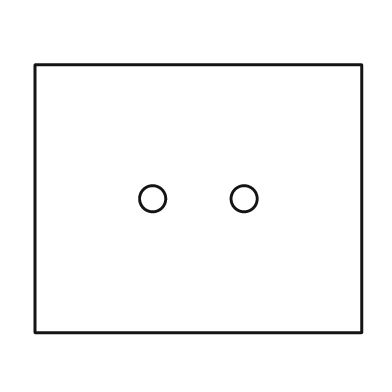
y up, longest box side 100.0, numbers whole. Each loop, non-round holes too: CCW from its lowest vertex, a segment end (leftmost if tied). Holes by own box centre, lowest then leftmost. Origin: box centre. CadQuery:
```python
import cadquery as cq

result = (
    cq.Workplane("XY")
    .moveTo(-50.0, -41.0)
    .lineTo(50.0, -41.0)
    .lineTo(50.0, 41.0)
    .lineTo(-50.0, 41.0)
    .close()
    .moveTo(-14.0, 0.0)
    .circle(4.0)
    .moveTo(14.0, 0.0)
    .circle(4.0)
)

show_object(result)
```